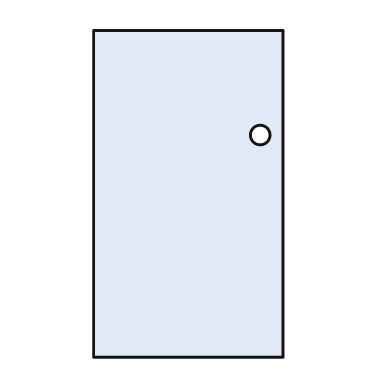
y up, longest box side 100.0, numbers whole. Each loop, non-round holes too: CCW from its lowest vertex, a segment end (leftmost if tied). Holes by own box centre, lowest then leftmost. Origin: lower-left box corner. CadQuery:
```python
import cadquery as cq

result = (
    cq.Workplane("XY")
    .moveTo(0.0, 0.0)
    .lineTo(58.0, 0.0)
    .lineTo(58.0, 100.0)
    .lineTo(0.0, 100.0)
    .close()
    .moveTo(51.0, 68.0)
    .circle(3.0)
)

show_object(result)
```